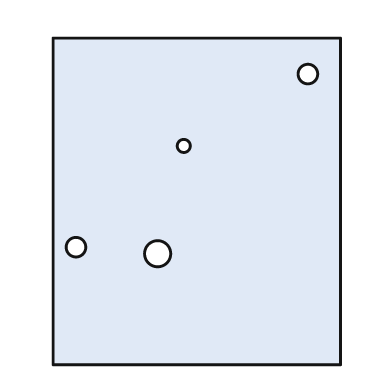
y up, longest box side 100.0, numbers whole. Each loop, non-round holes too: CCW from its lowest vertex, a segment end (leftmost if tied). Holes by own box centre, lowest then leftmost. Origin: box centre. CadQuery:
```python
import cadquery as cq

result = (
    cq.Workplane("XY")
    .moveTo(-44.0, -50.0)
    .lineTo(44.0, -50.0)
    .lineTo(44.0, 50.0)
    .lineTo(-44.0, 50.0)
    .close()
    .moveTo(-12.0, -16.0)
    .circle(4.0)
    .moveTo(-37.0, -14.0)
    .circle(3.0)
    .moveTo(-4.0, 17.0)
    .circle(2.0)
    .moveTo(34.0, 39.0)
    .circle(3.0)
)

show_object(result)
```